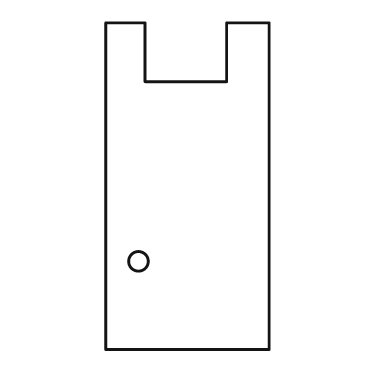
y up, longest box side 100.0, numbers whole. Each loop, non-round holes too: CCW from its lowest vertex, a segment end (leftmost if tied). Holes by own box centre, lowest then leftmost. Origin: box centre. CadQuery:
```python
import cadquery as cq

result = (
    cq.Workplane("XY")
    .moveTo(-25.0, -50.0)
    .lineTo(25.0, -50.0)
    .lineTo(25.0, 50.0)
    .lineTo(12.0, 50.0)
    .lineTo(12.0, 32.0)
    .lineTo(-13.0, 32.0)
    .lineTo(-13.0, 50.0)
    .lineTo(-25.0, 50.0)
    .close()
    .moveTo(-15.0, -23.0)
    .circle(3.0)
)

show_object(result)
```